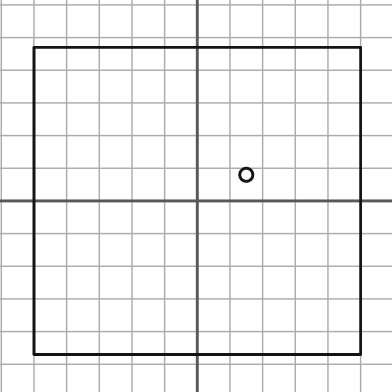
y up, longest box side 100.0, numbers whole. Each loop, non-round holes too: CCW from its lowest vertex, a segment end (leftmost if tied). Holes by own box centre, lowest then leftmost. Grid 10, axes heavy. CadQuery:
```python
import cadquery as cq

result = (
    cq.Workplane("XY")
    .moveTo(-50.0, -47.0)
    .lineTo(50.0, -47.0)
    .lineTo(50.0, 47.0)
    .lineTo(-50.0, 47.0)
    .close()
    .moveTo(15.0, 8.0)
    .circle(2.0)
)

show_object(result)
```